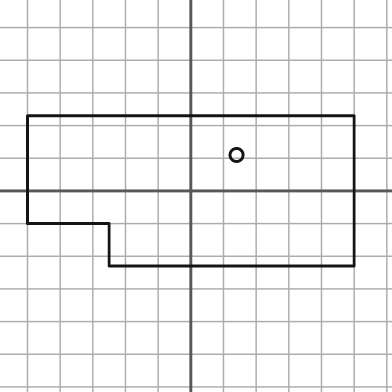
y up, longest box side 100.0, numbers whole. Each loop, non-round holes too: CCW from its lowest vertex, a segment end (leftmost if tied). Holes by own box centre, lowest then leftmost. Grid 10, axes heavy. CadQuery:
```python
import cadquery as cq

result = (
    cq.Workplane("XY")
    .moveTo(-25.0, -23.0)
    .lineTo(50.0, -23.0)
    .lineTo(50.0, 23.0)
    .lineTo(-50.0, 23.0)
    .lineTo(-50.0, -10.0)
    .lineTo(-25.0, -10.0)
    .close()
    .moveTo(14.0, 11.0)
    .circle(2.0)
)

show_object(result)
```